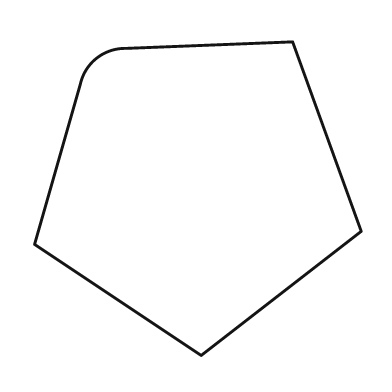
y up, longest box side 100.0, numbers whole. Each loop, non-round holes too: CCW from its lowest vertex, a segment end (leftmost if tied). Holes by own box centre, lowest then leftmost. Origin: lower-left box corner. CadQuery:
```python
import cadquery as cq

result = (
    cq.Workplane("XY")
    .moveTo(51.0, 0.0)
    .lineTo(100.0, 38.0)
    .lineTo(79.0, 96.0)
    .lineTo(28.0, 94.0)
    .threePointArc((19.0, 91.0), (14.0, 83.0))
    .lineTo(0.0, 34.0)
    .close()
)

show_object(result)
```